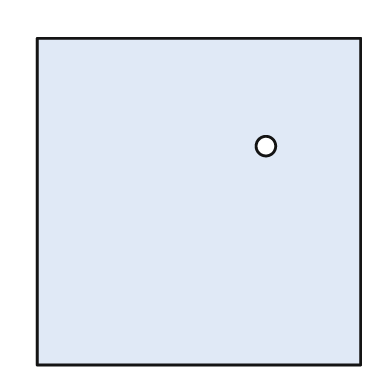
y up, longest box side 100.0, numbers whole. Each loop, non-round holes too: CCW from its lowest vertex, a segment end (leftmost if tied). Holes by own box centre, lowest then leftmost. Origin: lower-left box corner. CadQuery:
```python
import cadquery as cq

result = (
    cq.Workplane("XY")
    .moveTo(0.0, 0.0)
    .lineTo(99.0, 0.0)
    .lineTo(99.0, 100.0)
    .lineTo(0.0, 100.0)
    .close()
    .moveTo(70.0, 67.0)
    .circle(3.0)
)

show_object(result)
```